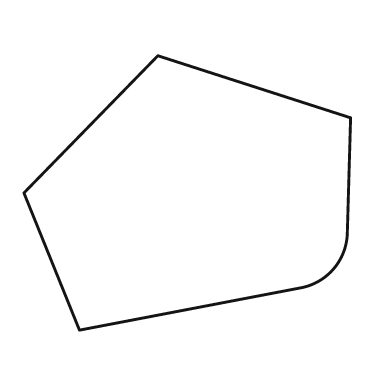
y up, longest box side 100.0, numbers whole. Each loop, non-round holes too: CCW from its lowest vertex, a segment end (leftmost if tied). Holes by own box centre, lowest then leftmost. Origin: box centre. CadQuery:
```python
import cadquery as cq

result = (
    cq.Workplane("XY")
    .moveTo(-33.0, -42.0)
    .lineTo(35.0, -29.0)
    .threePointArc((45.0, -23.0), (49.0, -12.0))
    .lineTo(50.0, 23.0)
    .lineTo(-9.0, 42.0)
    .lineTo(-50.0, 0.0)
    .close()
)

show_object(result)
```